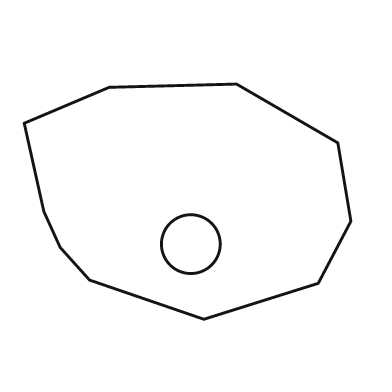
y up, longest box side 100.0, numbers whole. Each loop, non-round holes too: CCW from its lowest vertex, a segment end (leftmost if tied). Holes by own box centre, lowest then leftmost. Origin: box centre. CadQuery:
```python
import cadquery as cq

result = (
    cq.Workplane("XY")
    .moveTo(5.0, -36.0)
    .lineTo(40.0, -25.0)
    .lineTo(50.0, -6.0)
    .lineTo(46.0, 18.0)
    .lineTo(15.0, 36.0)
    .lineTo(-24.0, 35.0)
    .lineTo(-50.0, 24.0)
    .lineTo(-44.0, -3.0)
    .lineTo(-39.0, -14.0)
    .lineTo(-30.0, -24.0)
    .close()
    .moveTo(1.0, -13.0)
    .circle(9.0)
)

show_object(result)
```